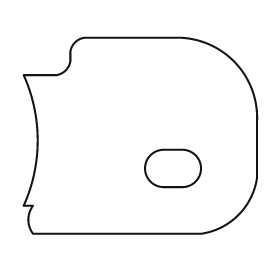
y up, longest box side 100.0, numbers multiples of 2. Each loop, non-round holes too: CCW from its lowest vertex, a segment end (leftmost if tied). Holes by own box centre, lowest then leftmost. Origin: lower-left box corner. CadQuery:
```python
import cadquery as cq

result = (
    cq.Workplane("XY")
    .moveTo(4.0, 0.0)
    .lineTo(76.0, 0.0)
    .threePointArc((92.0, 8.0), (100.0, 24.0))
    .lineTo(100.0, 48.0)
    .threePointArc((90.0, 74.0), (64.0, 84.0))
    .lineTo(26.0, 84.0)
    .threePointArc((22.0, 82.0), (20.0, 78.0))
    .lineTo(20.0, 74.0)
    .threePointArc((18.0, 70.0), (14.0, 68.0))
    .lineTo(0.0, 68.0)
    .threePointArc((6.0, 40.0), (0.0, 12.0))
    .lineTo(4.0, 12.0)
    .threePointArc((2.0, 6.0), (4.0, 0.0))
    .close()
    .moveTo(60.0, 20.0)
    .lineTo(68.0, 20.0)
    .threePointArc((76.0, 28.0), (68.0, 36.0))
    .lineTo(60.0, 36.0)
    .threePointArc((52.0, 28.0), (60.0, 20.0))
    .close()
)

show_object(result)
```